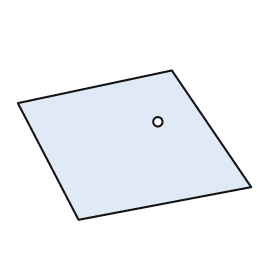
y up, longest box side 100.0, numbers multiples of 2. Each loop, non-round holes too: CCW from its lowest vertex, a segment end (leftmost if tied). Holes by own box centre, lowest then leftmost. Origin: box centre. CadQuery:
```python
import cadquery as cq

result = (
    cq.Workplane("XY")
    .moveTo(-24.0, -32.0)
    .lineTo(50.0, -18.0)
    .lineTo(16.0, 32.0)
    .lineTo(-50.0, 18.0)
    .close()
    .moveTo(10.0, 10.0)
    .circle(2.0)
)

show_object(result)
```